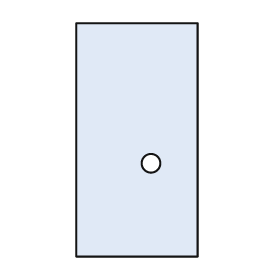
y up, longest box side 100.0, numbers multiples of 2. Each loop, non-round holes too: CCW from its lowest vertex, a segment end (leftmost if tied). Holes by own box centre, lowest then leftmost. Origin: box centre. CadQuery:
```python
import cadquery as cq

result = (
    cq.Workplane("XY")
    .moveTo(-26.0, -50.0)
    .lineTo(26.0, -50.0)
    .lineTo(26.0, 50.0)
    .lineTo(-26.0, 50.0)
    .close()
    .moveTo(6.0, -10.0)
    .circle(4.0)
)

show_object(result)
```